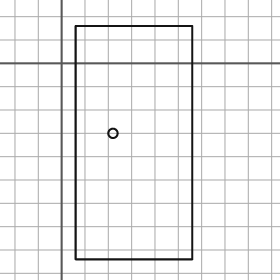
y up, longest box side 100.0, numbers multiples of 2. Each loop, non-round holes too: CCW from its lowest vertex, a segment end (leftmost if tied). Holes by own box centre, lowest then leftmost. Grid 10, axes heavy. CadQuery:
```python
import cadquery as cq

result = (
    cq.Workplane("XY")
    .moveTo(6.0, -84.0)
    .lineTo(56.0, -84.0)
    .lineTo(56.0, 16.0)
    .lineTo(6.0, 16.0)
    .close()
    .moveTo(22.0, -30.0)
    .circle(2.0)
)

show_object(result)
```